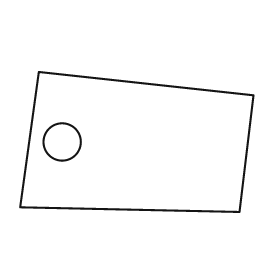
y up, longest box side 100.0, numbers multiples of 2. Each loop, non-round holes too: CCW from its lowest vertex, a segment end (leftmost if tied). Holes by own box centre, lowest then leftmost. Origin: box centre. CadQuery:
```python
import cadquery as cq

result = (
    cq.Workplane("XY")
    .moveTo(44.0, -30.0)
    .lineTo(50.0, 20.0)
    .lineTo(-42.0, 30.0)
    .lineTo(-50.0, -28.0)
    .close()
    .moveTo(-32.0, 0.0)
    .circle(8.0)
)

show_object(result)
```